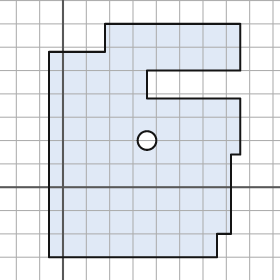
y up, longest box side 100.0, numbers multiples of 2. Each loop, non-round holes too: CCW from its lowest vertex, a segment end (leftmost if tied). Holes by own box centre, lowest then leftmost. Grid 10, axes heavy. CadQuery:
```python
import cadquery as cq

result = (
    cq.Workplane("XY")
    .moveTo(-6.0, -30.0)
    .lineTo(66.0, -30.0)
    .lineTo(66.0, -20.0)
    .lineTo(72.0, -20.0)
    .lineTo(72.0, 14.0)
    .lineTo(76.0, 14.0)
    .lineTo(76.0, 38.0)
    .lineTo(36.0, 38.0)
    .lineTo(36.0, 50.0)
    .lineTo(76.0, 50.0)
    .lineTo(76.0, 70.0)
    .lineTo(18.0, 70.0)
    .lineTo(18.0, 58.0)
    .lineTo(-6.0, 58.0)
    .close()
    .moveTo(36.0, 20.0)
    .circle(4.0)
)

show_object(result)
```